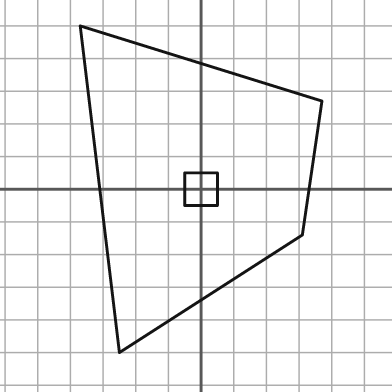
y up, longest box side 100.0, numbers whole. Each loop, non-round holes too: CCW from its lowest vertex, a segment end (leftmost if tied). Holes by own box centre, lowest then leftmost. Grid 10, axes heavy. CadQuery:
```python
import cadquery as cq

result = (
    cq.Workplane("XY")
    .moveTo(-25.0, -50.0)
    .lineTo(31.0, -14.0)
    .lineTo(37.0, 27.0)
    .lineTo(-37.0, 50.0)
    .close()
    .moveTo(-5.0, -5.0)
    .lineTo(5.0, -5.0)
    .lineTo(5.0, 5.0)
    .lineTo(-5.0, 5.0)
    .close()
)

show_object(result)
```